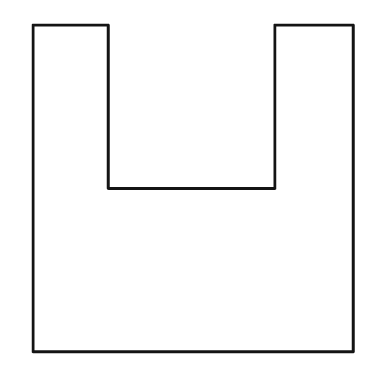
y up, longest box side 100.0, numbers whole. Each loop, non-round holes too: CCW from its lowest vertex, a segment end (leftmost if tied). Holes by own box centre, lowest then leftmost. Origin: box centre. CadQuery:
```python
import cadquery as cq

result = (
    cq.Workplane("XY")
    .moveTo(-49.0, -50.0)
    .lineTo(49.0, -50.0)
    .lineTo(49.0, 50.0)
    .lineTo(25.0, 50.0)
    .lineTo(25.0, 0.0)
    .lineTo(-26.0, 0.0)
    .lineTo(-26.0, 50.0)
    .lineTo(-49.0, 50.0)
    .close()
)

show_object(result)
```